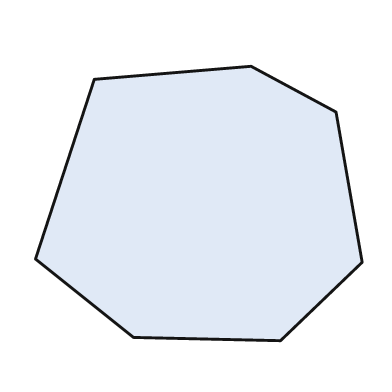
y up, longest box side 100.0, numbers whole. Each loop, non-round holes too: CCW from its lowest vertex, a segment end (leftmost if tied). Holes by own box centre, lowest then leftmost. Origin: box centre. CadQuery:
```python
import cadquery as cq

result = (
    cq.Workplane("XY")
    .moveTo(25.0, -42.0)
    .lineTo(50.0, -18.0)
    .lineTo(42.0, 28.0)
    .lineTo(16.0, 42.0)
    .lineTo(-32.0, 38.0)
    .lineTo(-50.0, -17.0)
    .lineTo(-20.0, -41.0)
    .close()
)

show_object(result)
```